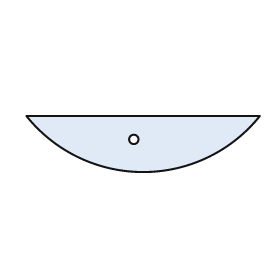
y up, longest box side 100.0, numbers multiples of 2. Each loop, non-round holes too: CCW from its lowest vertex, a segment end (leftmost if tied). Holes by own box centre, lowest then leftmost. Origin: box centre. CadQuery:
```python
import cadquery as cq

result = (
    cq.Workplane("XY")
    .moveTo(-50.0, 12.0)
    .threePointArc((0.0, -12.0), (50.0, 12.0))
    .close()
    .moveTo(-4.0, 2.0)
    .circle(2.0)
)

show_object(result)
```